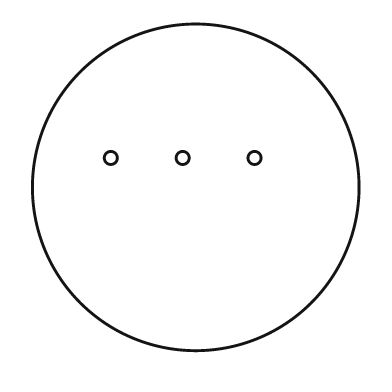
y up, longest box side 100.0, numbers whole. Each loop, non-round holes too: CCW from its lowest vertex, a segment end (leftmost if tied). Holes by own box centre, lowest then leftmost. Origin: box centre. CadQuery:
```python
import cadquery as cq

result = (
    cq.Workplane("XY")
    .moveTo(0.0, 0.0)
    .circle(50.0)
    .moveTo(-26.0, 9.0)
    .circle(2.0)
    .moveTo(-4.0, 9.0)
    .circle(2.0)
    .moveTo(18.0, 9.0)
    .circle(2.0)
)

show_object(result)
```